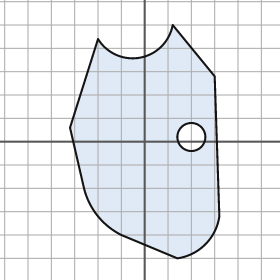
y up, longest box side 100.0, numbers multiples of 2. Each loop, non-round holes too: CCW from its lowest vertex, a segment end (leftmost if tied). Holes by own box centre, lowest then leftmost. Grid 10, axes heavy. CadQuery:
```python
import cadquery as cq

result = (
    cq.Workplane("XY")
    .moveTo(14.0, -50.0)
    .threePointArc((26.0, -44.0), (32.0, -32.0))
    .lineTo(30.0, 28.0)
    .lineTo(12.0, 50.0)
    .threePointArc((-2.0, 36.0), (-20.0, 44.0))
    .lineTo(-32.0, 6.0)
    .lineTo(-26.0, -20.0)
    .threePointArc((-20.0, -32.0), (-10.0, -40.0))
    .close()
    .moveTo(20.0, 2.0)
    .circle(6.0)
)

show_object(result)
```